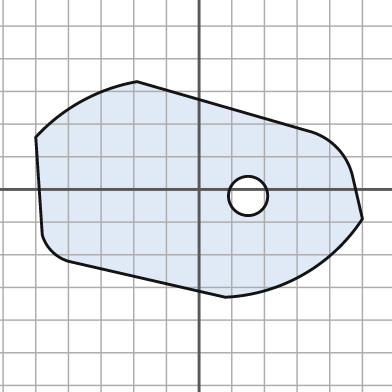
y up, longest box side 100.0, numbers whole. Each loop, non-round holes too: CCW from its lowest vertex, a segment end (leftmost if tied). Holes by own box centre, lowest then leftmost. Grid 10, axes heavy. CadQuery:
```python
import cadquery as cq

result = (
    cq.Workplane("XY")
    .moveTo(8.0, -33.0)
    .threePointArc((32.0, -26.0), (50.0, -9.0))
    .lineTo(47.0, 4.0)
    .threePointArc((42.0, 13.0), (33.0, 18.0))
    .lineTo(-19.0, 33.0)
    .threePointArc((-36.0, 27.0), (-50.0, 16.0))
    .lineTo(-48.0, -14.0)
    .threePointArc((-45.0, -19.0), (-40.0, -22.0))
    .close()
    .moveTo(15.0, -2.0)
    .circle(6.0)
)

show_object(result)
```